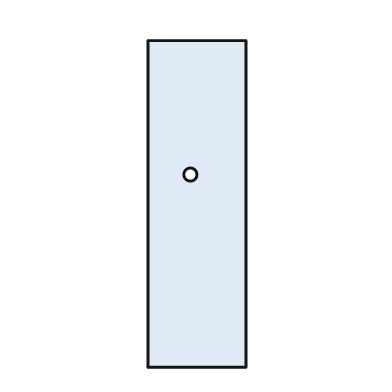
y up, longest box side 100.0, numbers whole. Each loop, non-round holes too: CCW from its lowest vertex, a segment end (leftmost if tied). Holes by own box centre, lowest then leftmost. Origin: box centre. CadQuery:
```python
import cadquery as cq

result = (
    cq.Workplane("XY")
    .moveTo(-15.0, -50.0)
    .lineTo(15.0, -50.0)
    .lineTo(15.0, 50.0)
    .lineTo(-15.0, 50.0)
    .close()
    .moveTo(-2.0, 9.0)
    .circle(2.0)
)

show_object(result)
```